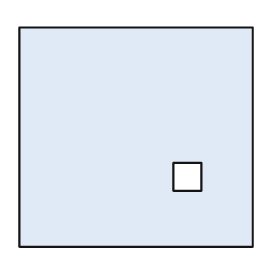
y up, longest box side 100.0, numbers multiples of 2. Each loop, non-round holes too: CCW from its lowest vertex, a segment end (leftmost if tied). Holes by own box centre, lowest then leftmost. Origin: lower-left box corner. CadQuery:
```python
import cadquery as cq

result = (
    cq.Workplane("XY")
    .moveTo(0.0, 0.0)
    .lineTo(100.0, 0.0)
    .lineTo(100.0, 94.0)
    .lineTo(0.0, 94.0)
    .close()
    .moveTo(66.0, 24.0)
    .lineTo(78.0, 24.0)
    .lineTo(78.0, 36.0)
    .lineTo(66.0, 36.0)
    .close()
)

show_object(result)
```